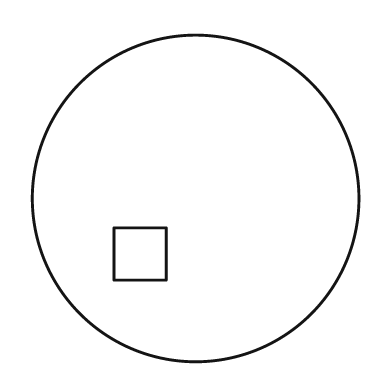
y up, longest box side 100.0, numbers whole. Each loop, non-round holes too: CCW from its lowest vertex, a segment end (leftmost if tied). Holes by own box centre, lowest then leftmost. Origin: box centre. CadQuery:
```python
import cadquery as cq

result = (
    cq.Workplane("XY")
    .moveTo(0.0, 0.0)
    .circle(50.0)
    .moveTo(-25.0, -25.0)
    .lineTo(-9.0, -25.0)
    .lineTo(-9.0, -9.0)
    .lineTo(-25.0, -9.0)
    .close()
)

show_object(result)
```